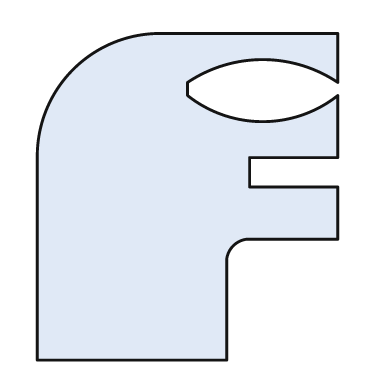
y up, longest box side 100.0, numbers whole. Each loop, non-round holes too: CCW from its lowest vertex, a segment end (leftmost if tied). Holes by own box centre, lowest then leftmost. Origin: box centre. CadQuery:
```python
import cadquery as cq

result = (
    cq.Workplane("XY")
    .moveTo(-46.0, -50.0)
    .lineTo(12.0, -50.0)
    .lineTo(12.0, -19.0)
    .threePointArc((14.0, -15.0), (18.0, -13.0))
    .lineTo(46.0, -13.0)
    .lineTo(46.0, 3.0)
    .lineTo(19.0, 3.0)
    .lineTo(19.0, 12.0)
    .lineTo(46.0, 12.0)
    .lineTo(46.0, 31.0)
    .threePointArc((23.0, 23.0), (0.0, 31.0))
    .lineTo(0.0, 35.0)
    .threePointArc((23.0, 42.0), (46.0, 35.0))
    .lineTo(46.0, 50.0)
    .lineTo(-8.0, 50.0)
    .threePointArc((-35.0, 39.0), (-46.0, 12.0))
    .close()
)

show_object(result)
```